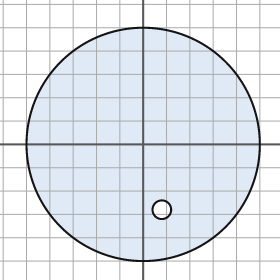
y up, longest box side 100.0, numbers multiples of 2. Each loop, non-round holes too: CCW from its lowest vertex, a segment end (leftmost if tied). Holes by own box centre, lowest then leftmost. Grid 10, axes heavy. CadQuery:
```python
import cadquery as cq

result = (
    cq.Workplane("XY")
    .moveTo(0.0, 0.0)
    .circle(50.0)
    .moveTo(8.0, -28.0)
    .circle(4.0)
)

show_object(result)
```